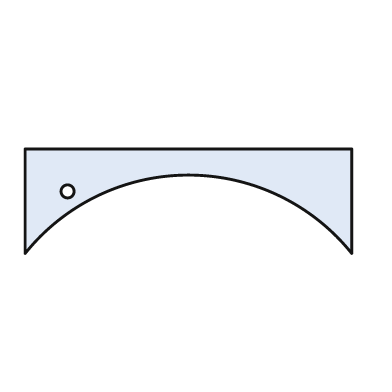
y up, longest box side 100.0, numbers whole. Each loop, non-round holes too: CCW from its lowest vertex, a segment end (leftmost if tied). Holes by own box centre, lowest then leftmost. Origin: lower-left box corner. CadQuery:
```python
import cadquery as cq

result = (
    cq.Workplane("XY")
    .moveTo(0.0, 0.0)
    .threePointArc((50.0, 24.0), (100.0, 0.0))
    .lineTo(100.0, 32.0)
    .lineTo(0.0, 32.0)
    .close()
    .moveTo(13.0, 19.0)
    .circle(2.0)
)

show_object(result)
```